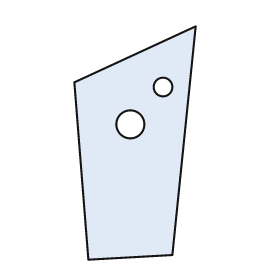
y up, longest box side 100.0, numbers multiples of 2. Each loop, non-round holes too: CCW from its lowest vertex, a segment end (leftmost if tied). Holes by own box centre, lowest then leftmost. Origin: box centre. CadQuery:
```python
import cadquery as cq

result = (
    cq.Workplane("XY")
    .moveTo(-20.0, -50.0)
    .lineTo(16.0, -48.0)
    .lineTo(26.0, 50.0)
    .lineTo(-26.0, 26.0)
    .close()
    .moveTo(-2.0, 8.0)
    .circle(6.0)
    .moveTo(12.0, 24.0)
    .circle(4.0)
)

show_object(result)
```